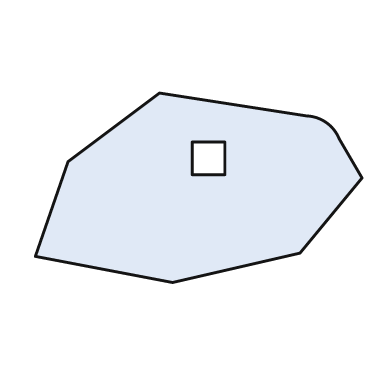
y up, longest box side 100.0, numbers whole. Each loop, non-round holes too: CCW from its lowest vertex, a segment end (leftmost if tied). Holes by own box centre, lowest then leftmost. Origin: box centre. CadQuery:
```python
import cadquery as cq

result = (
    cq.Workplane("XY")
    .moveTo(-8.0, -29.0)
    .lineTo(31.0, -20.0)
    .lineTo(50.0, 3.0)
    .lineTo(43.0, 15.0)
    .threePointArc((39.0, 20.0), (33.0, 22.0))
    .lineTo(-12.0, 29.0)
    .lineTo(-40.0, 8.0)
    .lineTo(-50.0, -21.0)
    .close()
    .moveTo(-2.0, 4.0)
    .lineTo(8.0, 4.0)
    .lineTo(8.0, 14.0)
    .lineTo(-2.0, 14.0)
    .close()
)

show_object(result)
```